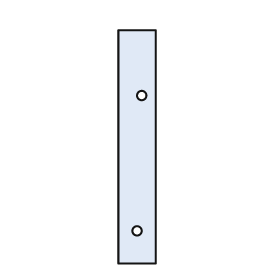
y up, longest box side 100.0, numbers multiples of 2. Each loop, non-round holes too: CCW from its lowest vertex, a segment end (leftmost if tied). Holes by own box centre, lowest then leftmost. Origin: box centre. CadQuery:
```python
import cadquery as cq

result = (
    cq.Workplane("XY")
    .moveTo(-8.0, -50.0)
    .lineTo(8.0, -50.0)
    .lineTo(8.0, 50.0)
    .lineTo(-8.0, 50.0)
    .close()
    .moveTo(0.0, -36.0)
    .circle(2.0)
    .moveTo(2.0, 22.0)
    .circle(2.0)
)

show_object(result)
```